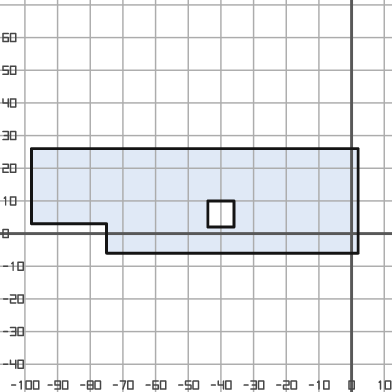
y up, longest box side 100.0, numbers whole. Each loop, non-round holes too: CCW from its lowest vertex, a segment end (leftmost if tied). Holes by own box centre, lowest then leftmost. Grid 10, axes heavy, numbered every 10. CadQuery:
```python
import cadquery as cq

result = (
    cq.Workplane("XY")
    .moveTo(-75.0, -6.0)
    .lineTo(2.0, -6.0)
    .lineTo(2.0, 26.0)
    .lineTo(-98.0, 26.0)
    .lineTo(-98.0, 3.0)
    .lineTo(-75.0, 3.0)
    .close()
    .moveTo(-44.0, 2.0)
    .lineTo(-36.0, 2.0)
    .lineTo(-36.0, 10.0)
    .lineTo(-44.0, 10.0)
    .close()
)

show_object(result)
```